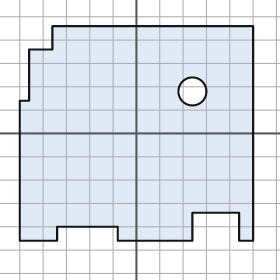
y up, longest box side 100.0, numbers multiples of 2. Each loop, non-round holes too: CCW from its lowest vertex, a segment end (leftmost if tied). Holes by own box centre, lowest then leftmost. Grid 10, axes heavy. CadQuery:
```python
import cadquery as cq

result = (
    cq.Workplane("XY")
    .moveTo(-50.0, -46.0)
    .lineTo(-34.0, -46.0)
    .lineTo(-34.0, -40.0)
    .lineTo(-8.0, -40.0)
    .lineTo(-8.0, -46.0)
    .lineTo(24.0, -46.0)
    .lineTo(24.0, -34.0)
    .lineTo(44.0, -34.0)
    .lineTo(44.0, -46.0)
    .lineTo(50.0, -46.0)
    .lineTo(50.0, 46.0)
    .lineTo(-36.0, 46.0)
    .lineTo(-36.0, 36.0)
    .lineTo(-46.0, 36.0)
    .lineTo(-46.0, 14.0)
    .lineTo(-50.0, 14.0)
    .close()
    .moveTo(24.0, 18.0)
    .circle(6.0)
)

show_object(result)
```